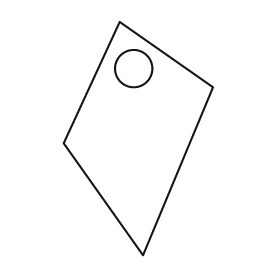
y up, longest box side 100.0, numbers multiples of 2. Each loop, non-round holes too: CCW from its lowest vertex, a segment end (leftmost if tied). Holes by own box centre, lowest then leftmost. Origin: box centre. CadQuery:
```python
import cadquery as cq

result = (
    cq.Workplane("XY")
    .moveTo(2.0, -50.0)
    .lineTo(32.0, 22.0)
    .lineTo(-8.0, 50.0)
    .lineTo(-32.0, -2.0)
    .close()
    .moveTo(-2.0, 30.0)
    .circle(8.0)
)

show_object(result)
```